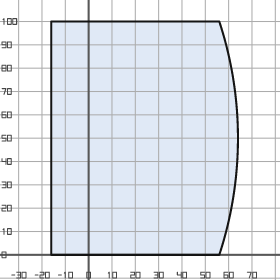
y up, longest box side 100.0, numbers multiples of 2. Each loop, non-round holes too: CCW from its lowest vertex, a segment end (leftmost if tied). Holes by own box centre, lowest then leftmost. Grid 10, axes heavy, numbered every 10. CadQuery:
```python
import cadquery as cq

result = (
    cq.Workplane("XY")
    .moveTo(-16.0, 0.0)
    .lineTo(56.0, 0.0)
    .threePointArc((64.0, 50.0), (56.0, 100.0))
    .lineTo(-16.0, 100.0)
    .close()
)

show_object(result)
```